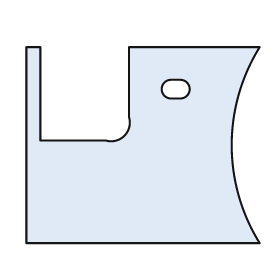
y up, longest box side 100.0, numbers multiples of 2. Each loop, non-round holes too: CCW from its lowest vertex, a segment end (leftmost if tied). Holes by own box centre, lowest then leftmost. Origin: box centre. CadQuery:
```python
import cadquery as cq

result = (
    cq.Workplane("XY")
    .moveTo(-50.0, -42.0)
    .lineTo(50.0, -42.0)
    .threePointArc((38.0, 0.0), (50.0, 42.0))
    .lineTo(-6.0, 42.0)
    .lineTo(-6.0, 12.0)
    .threePointArc((-8.0, 4.0), (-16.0, 2.0))
    .lineTo(-44.0, 2.0)
    .lineTo(-44.0, 42.0)
    .lineTo(-50.0, 42.0)
    .close()
    .moveTo(12.0, 20.0)
    .lineTo(16.0, 20.0)
    .threePointArc((20.0, 24.0), (16.0, 28.0))
    .lineTo(12.0, 28.0)
    .threePointArc((8.0, 24.0), (12.0, 20.0))
    .close()
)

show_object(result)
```